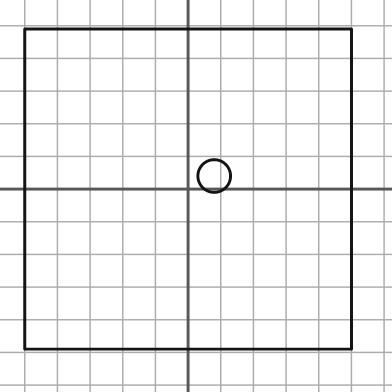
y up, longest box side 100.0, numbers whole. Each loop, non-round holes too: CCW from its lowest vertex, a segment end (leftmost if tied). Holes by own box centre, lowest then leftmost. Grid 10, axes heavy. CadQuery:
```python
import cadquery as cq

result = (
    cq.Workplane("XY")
    .moveTo(-50.0, -49.0)
    .lineTo(50.0, -49.0)
    .lineTo(50.0, 49.0)
    .lineTo(-50.0, 49.0)
    .close()
    .moveTo(8.0, 4.0)
    .circle(5.0)
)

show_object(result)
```